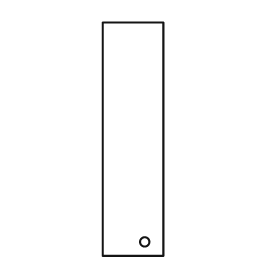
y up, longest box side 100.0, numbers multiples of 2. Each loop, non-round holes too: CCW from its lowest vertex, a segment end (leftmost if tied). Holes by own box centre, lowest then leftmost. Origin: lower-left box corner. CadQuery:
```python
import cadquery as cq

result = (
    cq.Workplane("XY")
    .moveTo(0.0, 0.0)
    .lineTo(26.0, 0.0)
    .lineTo(26.0, 100.0)
    .lineTo(0.0, 100.0)
    .close()
    .moveTo(18.0, 6.0)
    .circle(2.0)
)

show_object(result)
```